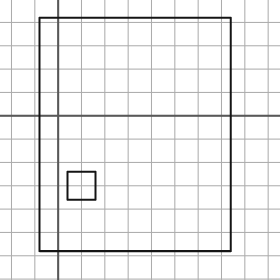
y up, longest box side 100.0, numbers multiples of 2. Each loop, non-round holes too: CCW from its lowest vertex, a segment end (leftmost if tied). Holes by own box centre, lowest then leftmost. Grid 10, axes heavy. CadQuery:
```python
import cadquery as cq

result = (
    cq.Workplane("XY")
    .moveTo(-8.0, -58.0)
    .lineTo(74.0, -58.0)
    .lineTo(74.0, 42.0)
    .lineTo(-8.0, 42.0)
    .close()
    .moveTo(4.0, -36.0)
    .lineTo(16.0, -36.0)
    .lineTo(16.0, -24.0)
    .lineTo(4.0, -24.0)
    .close()
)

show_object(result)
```